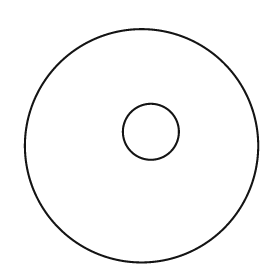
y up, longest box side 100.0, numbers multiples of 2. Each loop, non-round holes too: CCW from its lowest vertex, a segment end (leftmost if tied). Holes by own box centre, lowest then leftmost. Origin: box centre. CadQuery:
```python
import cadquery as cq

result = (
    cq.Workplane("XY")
    .moveTo(0.0, 0.0)
    .circle(50.0)
    .moveTo(4.0, 6.0)
    .circle(12.0)
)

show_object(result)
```